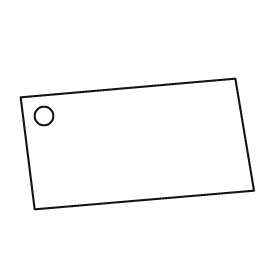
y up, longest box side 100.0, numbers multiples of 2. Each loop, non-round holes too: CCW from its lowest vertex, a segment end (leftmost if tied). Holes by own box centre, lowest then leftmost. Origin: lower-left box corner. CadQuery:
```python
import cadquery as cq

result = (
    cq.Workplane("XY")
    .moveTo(6.0, 0.0)
    .lineTo(100.0, 8.0)
    .lineTo(92.0, 56.0)
    .lineTo(0.0, 48.0)
    .close()
    .moveTo(10.0, 40.0)
    .circle(4.0)
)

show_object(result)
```